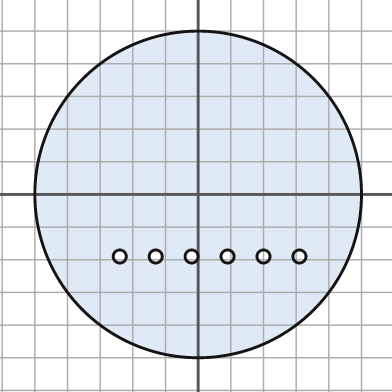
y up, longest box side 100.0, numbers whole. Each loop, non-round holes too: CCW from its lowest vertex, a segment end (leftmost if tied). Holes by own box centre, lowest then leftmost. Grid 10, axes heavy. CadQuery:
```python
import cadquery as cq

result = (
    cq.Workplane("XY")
    .moveTo(0.0, 0.0)
    .circle(50.0)
    .moveTo(-24.0, -19.0)
    .circle(2.0)
    .moveTo(-13.0, -19.0)
    .circle(2.0)
    .moveTo(-2.0, -19.0)
    .circle(2.0)
    .moveTo(9.0, -19.0)
    .circle(2.0)
    .moveTo(20.0, -19.0)
    .circle(2.0)
    .moveTo(31.0, -19.0)
    .circle(2.0)
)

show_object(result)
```